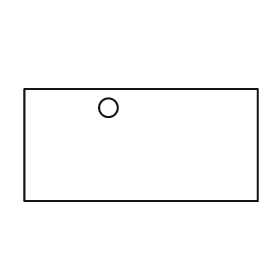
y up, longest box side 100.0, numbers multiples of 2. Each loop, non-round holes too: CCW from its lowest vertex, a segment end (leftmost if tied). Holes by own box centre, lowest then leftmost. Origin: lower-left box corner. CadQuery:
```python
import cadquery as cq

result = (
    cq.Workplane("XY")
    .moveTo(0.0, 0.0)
    .lineTo(100.0, 0.0)
    .lineTo(100.0, 48.0)
    .lineTo(0.0, 48.0)
    .close()
    .moveTo(36.0, 40.0)
    .circle(4.0)
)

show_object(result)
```